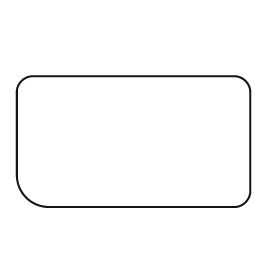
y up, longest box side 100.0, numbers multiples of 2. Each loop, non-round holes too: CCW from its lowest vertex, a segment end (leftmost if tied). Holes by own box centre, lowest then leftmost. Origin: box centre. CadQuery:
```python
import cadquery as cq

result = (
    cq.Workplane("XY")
    .moveTo(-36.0, -28.0)
    .lineTo(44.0, -28.0)
    .threePointArc((48.0, -26.0), (50.0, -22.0))
    .lineTo(50.0, 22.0)
    .threePointArc((48.0, 26.0), (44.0, 28.0))
    .lineTo(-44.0, 28.0)
    .threePointArc((-48.0, 26.0), (-50.0, 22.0))
    .lineTo(-50.0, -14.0)
    .threePointArc((-46.0, -24.0), (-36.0, -28.0))
    .close()
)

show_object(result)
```